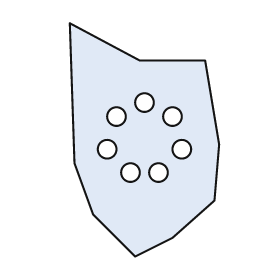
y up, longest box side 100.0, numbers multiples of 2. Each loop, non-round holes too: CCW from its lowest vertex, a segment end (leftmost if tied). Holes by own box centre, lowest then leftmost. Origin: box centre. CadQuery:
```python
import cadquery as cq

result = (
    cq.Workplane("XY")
    .moveTo(-4.0, -50.0)
    .lineTo(12.0, -42.0)
    .lineTo(30.0, -26.0)
    .lineTo(32.0, -2.0)
    .lineTo(26.0, 34.0)
    .lineTo(-2.0, 34.0)
    .lineTo(-32.0, 50.0)
    .lineTo(-30.0, -10.0)
    .lineTo(-22.0, -32.0)
    .close()
    .moveTo(-6.0, -14.0)
    .circle(4.0)
    .moveTo(6.0, -14.0)
    .circle(4.0)
    .moveTo(-16.0, -4.0)
    .circle(4.0)
    .moveTo(16.0, -4.0)
    .circle(4.0)
    .moveTo(-12.0, 10.0)
    .circle(4.0)
    .moveTo(12.0, 10.0)
    .circle(4.0)
    .moveTo(0.0, 16.0)
    .circle(4.0)
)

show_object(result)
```